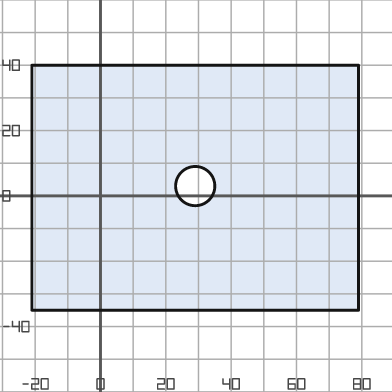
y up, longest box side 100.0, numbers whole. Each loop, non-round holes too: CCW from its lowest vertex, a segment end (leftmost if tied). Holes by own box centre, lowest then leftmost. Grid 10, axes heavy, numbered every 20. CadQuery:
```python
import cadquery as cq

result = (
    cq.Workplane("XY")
    .moveTo(-21.0, -35.0)
    .lineTo(79.0, -35.0)
    .lineTo(79.0, 40.0)
    .lineTo(-21.0, 40.0)
    .close()
    .moveTo(29.0, 3.0)
    .circle(6.0)
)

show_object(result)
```